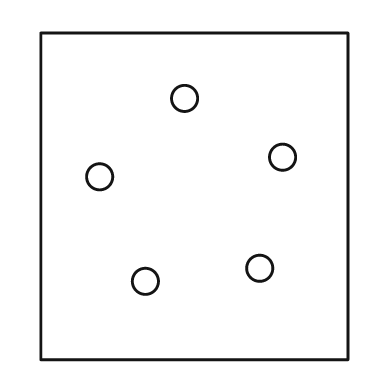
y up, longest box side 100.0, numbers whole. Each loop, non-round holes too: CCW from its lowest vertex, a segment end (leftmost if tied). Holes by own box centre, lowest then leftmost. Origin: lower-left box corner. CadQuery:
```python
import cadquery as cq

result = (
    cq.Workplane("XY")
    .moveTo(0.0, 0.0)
    .lineTo(94.0, 0.0)
    .lineTo(94.0, 100.0)
    .lineTo(0.0, 100.0)
    .close()
    .moveTo(32.0, 24.0)
    .circle(4.0)
    .moveTo(67.0, 28.0)
    .circle(4.0)
    .moveTo(18.0, 56.0)
    .circle(4.0)
    .moveTo(74.0, 62.0)
    .circle(4.0)
    .moveTo(44.0, 80.0)
    .circle(4.0)
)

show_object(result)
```